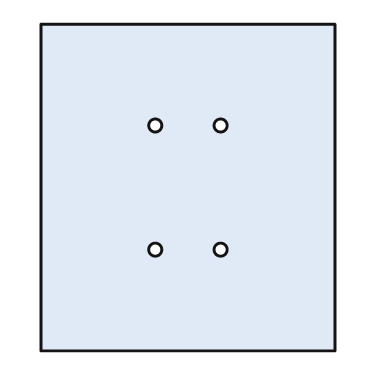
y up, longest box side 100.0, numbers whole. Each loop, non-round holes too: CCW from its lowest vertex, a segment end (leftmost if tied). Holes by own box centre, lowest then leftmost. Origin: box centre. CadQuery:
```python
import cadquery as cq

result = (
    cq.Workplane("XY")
    .moveTo(-45.0, -50.0)
    .lineTo(45.0, -50.0)
    .lineTo(45.0, 50.0)
    .lineTo(-45.0, 50.0)
    .close()
    .moveTo(-10.0, -19.0)
    .circle(2.0)
    .moveTo(10.0, -19.0)
    .circle(2.0)
    .moveTo(-10.0, 19.0)
    .circle(2.0)
    .moveTo(10.0, 19.0)
    .circle(2.0)
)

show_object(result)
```